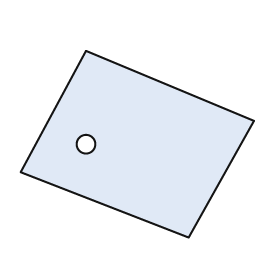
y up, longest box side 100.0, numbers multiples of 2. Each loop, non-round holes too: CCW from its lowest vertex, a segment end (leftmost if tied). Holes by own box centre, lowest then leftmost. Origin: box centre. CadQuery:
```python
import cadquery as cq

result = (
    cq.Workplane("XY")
    .moveTo(22.0, -40.0)
    .lineTo(50.0, 10.0)
    .lineTo(-22.0, 40.0)
    .lineTo(-50.0, -12.0)
    .close()
    .moveTo(-22.0, 0.0)
    .circle(4.0)
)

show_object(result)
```